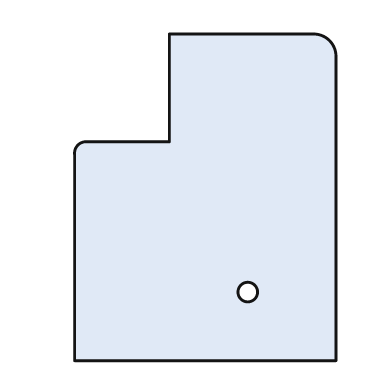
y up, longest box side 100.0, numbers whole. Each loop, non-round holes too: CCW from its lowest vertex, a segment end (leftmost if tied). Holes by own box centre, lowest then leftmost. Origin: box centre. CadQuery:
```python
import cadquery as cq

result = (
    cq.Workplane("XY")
    .moveTo(-40.0, -50.0)
    .lineTo(40.0, -50.0)
    .lineTo(40.0, 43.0)
    .threePointArc((38.0, 48.0), (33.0, 50.0))
    .lineTo(-11.0, 50.0)
    .lineTo(-11.0, 17.0)
    .lineTo(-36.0, 17.0)
    .threePointArc((-39.0, 16.0), (-40.0, 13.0))
    .close()
    .moveTo(13.0, -29.0)
    .circle(3.0)
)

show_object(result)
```